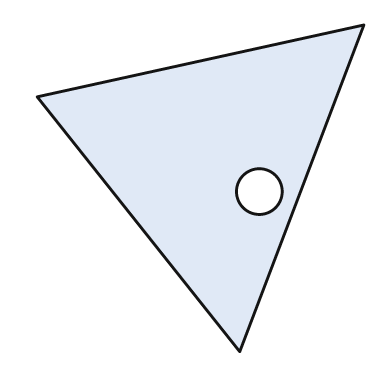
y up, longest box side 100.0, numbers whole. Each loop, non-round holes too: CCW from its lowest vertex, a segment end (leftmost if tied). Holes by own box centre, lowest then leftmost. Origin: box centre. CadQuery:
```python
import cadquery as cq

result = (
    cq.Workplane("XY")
    .moveTo(12.0, -50.0)
    .lineTo(50.0, 50.0)
    .lineTo(-50.0, 28.0)
    .close()
    .moveTo(18.0, -1.0)
    .circle(7.0)
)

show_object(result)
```